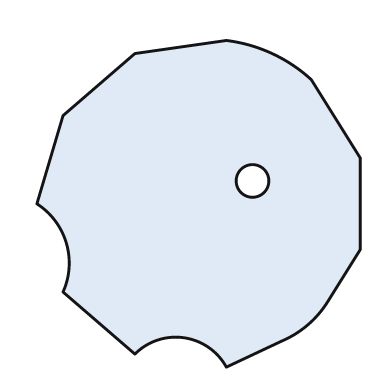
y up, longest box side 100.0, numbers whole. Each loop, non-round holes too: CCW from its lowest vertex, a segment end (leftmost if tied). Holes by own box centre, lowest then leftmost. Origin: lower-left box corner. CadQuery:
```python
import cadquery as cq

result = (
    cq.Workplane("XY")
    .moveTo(58.0, 0.0)
    .lineTo(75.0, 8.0)
    .threePointArc((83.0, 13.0), (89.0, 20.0))
    .lineTo(99.0, 36.0)
    .lineTo(99.0, 64.0)
    .lineTo(84.0, 88.0)
    .threePointArc((72.0, 96.0), (58.0, 100.0))
    .lineTo(30.0, 96.0)
    .lineTo(8.0, 77.0)
    .lineTo(0.0, 50.0)
    .threePointArc((9.0, 38.0), (8.0, 23.0))
    .lineTo(30.0, 4.0)
    .threePointArc((45.0, 9.0), (58.0, 0.0))
    .close()
    .moveTo(66.0, 57.0)
    .circle(5.0)
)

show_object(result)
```